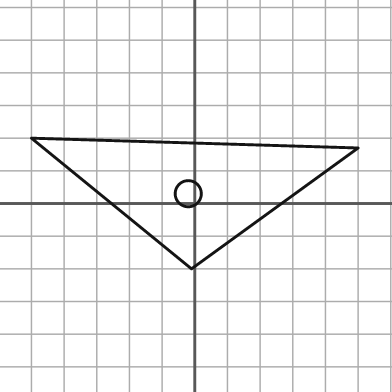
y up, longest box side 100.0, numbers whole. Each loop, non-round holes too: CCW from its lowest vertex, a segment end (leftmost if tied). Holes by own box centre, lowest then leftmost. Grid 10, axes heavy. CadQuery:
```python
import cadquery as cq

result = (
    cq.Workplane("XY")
    .moveTo(-1.0, -20.0)
    .lineTo(50.0, 17.0)
    .lineTo(-50.0, 20.0)
    .close()
    .moveTo(-2.0, 3.0)
    .circle(4.0)
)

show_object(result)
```